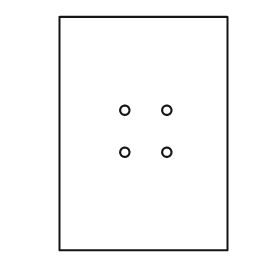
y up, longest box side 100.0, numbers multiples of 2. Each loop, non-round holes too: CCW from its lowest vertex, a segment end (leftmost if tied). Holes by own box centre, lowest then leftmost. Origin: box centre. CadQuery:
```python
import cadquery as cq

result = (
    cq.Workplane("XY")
    .moveTo(-36.0, -50.0)
    .lineTo(36.0, -50.0)
    .lineTo(36.0, 50.0)
    .lineTo(-36.0, 50.0)
    .close()
    .moveTo(-8.0, -8.0)
    .circle(2.0)
    .moveTo(10.0, -8.0)
    .circle(2.0)
    .moveTo(-8.0, 10.0)
    .circle(2.0)
    .moveTo(10.0, 10.0)
    .circle(2.0)
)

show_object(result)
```